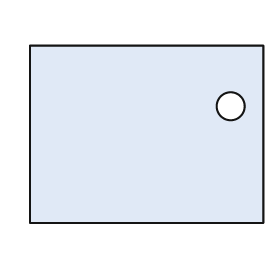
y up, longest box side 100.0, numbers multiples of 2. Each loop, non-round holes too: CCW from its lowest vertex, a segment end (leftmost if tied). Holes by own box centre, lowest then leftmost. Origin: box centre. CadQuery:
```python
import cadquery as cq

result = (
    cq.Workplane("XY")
    .moveTo(-50.0, -38.0)
    .lineTo(50.0, -38.0)
    .lineTo(50.0, 38.0)
    .lineTo(-50.0, 38.0)
    .close()
    .moveTo(36.0, 12.0)
    .circle(6.0)
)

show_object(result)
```